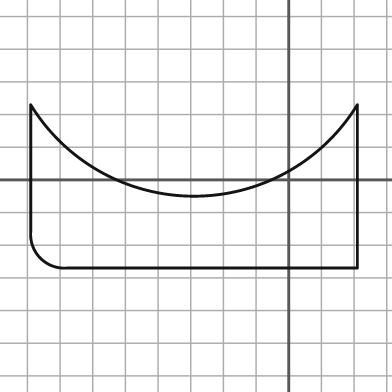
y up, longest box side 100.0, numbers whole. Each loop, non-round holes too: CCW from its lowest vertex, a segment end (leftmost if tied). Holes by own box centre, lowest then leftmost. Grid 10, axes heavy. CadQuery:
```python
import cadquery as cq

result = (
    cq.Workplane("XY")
    .moveTo(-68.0, -27.0)
    .lineTo(21.0, -27.0)
    .lineTo(21.0, 23.0)
    .threePointArc((-29.0, -5.0), (-79.0, 23.0))
    .lineTo(-79.0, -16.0)
    .threePointArc((-76.0, -24.0), (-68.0, -27.0))
    .close()
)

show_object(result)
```